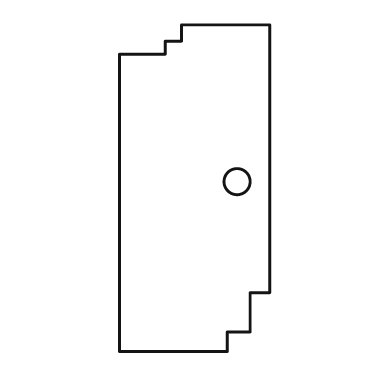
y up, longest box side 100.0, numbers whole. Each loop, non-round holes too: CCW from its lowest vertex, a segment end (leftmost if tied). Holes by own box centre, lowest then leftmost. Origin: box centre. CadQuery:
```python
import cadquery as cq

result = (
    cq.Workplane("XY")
    .moveTo(-23.0, -50.0)
    .lineTo(10.0, -50.0)
    .lineTo(10.0, -44.0)
    .lineTo(17.0, -44.0)
    .lineTo(17.0, -32.0)
    .lineTo(23.0, -32.0)
    .lineTo(23.0, 50.0)
    .lineTo(-4.0, 50.0)
    .lineTo(-4.0, 45.0)
    .lineTo(-9.0, 45.0)
    .lineTo(-9.0, 41.0)
    .lineTo(-23.0, 41.0)
    .close()
    .moveTo(13.0, 2.0)
    .circle(4.0)
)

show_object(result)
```